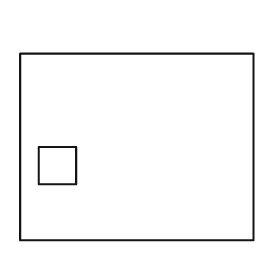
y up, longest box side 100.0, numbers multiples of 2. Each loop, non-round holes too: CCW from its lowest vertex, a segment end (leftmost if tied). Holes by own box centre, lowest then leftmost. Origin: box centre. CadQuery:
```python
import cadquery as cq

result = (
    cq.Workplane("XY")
    .moveTo(-50.0, -40.0)
    .lineTo(50.0, -40.0)
    .lineTo(50.0, 40.0)
    .lineTo(-50.0, 40.0)
    .close()
    .moveTo(-42.0, -16.0)
    .lineTo(-26.0, -16.0)
    .lineTo(-26.0, 0.0)
    .lineTo(-42.0, 0.0)
    .close()
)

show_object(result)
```